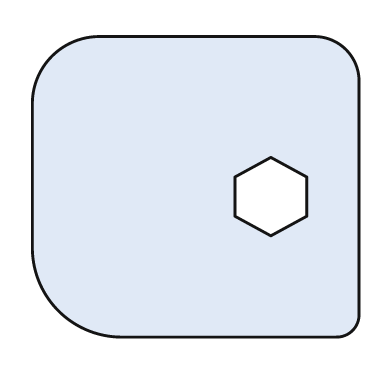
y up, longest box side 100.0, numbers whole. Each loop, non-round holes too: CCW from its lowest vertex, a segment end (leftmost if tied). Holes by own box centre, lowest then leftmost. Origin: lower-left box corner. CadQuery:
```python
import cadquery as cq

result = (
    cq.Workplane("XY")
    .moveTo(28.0, 0.0)
    .lineTo(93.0, 0.0)
    .threePointArc((98.0, 2.0), (100.0, 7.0))
    .lineTo(100.0, 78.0)
    .threePointArc((96.0, 88.0), (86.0, 92.0))
    .lineTo(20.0, 92.0)
    .threePointArc((6.0, 86.0), (0.0, 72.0))
    .lineTo(0.0, 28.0)
    .threePointArc((8.0, 8.0), (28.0, 0.0))
    .close()
    .moveTo(73.0, 31.0)
    .lineTo(84.0, 37.0)
    .lineTo(84.0, 49.0)
    .lineTo(73.0, 55.0)
    .lineTo(62.0, 49.0)
    .lineTo(62.0, 37.0)
    .close()
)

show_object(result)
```